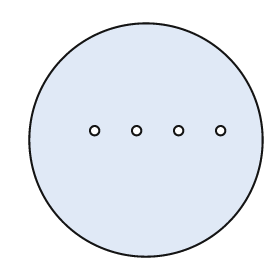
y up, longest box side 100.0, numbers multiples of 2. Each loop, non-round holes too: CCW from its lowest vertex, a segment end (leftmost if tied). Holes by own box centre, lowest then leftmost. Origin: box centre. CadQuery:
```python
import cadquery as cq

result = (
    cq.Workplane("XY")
    .moveTo(0.0, 0.0)
    .circle(50.0)
    .moveTo(-22.0, 4.0)
    .circle(2.0)
    .moveTo(-4.0, 4.0)
    .circle(2.0)
    .moveTo(14.0, 4.0)
    .circle(2.0)
    .moveTo(32.0, 4.0)
    .circle(2.0)
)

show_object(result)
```